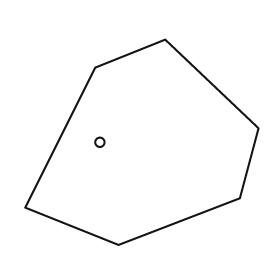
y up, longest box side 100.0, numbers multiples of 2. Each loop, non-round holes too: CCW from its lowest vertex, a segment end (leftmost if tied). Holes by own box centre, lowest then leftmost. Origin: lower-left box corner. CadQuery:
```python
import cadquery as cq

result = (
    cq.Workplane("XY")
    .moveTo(40.0, 0.0)
    .lineTo(92.0, 20.0)
    .lineTo(100.0, 50.0)
    .lineTo(60.0, 88.0)
    .lineTo(30.0, 76.0)
    .lineTo(0.0, 16.0)
    .close()
    .moveTo(32.0, 44.0)
    .circle(2.0)
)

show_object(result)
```